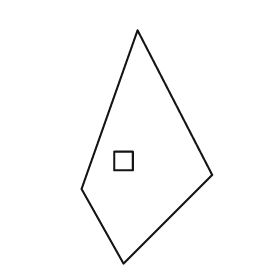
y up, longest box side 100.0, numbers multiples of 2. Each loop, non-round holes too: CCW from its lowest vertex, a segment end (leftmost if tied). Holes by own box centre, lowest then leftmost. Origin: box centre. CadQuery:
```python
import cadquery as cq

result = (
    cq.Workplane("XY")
    .moveTo(-10.0, -50.0)
    .lineTo(28.0, -12.0)
    .lineTo(-4.0, 50.0)
    .lineTo(-28.0, -18.0)
    .close()
    .moveTo(-14.0, -10.0)
    .lineTo(-6.0, -10.0)
    .lineTo(-6.0, -2.0)
    .lineTo(-14.0, -2.0)
    .close()
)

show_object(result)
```